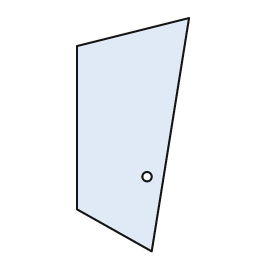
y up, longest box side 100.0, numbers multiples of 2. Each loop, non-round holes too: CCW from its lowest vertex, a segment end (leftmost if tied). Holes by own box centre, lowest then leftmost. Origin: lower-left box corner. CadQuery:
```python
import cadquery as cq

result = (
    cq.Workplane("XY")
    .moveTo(32.0, 0.0)
    .lineTo(48.0, 100.0)
    .lineTo(0.0, 88.0)
    .lineTo(0.0, 18.0)
    .close()
    .moveTo(30.0, 32.0)
    .circle(2.0)
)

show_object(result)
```